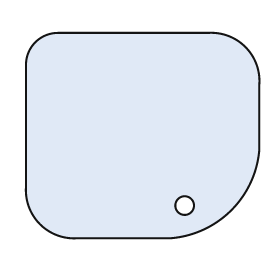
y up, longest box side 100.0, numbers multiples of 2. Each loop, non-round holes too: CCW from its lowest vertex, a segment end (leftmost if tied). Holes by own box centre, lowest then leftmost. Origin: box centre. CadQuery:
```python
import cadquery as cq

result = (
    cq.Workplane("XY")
    .moveTo(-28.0, -44.0)
    .lineTo(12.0, -44.0)
    .threePointArc((38.0, -32.0), (50.0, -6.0))
    .lineTo(50.0, 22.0)
    .threePointArc((44.0, 38.0), (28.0, 44.0))
    .lineTo(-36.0, 44.0)
    .threePointArc((-46.0, 40.0), (-50.0, 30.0))
    .lineTo(-50.0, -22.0)
    .threePointArc((-44.0, -38.0), (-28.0, -44.0))
    .close()
    .moveTo(18.0, -30.0)
    .circle(4.0)
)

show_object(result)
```